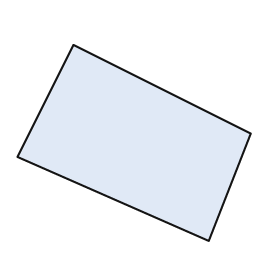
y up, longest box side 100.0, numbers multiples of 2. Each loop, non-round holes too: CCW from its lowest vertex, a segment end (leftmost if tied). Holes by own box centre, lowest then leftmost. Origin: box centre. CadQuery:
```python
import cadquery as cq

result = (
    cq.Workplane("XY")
    .moveTo(32.0, -42.0)
    .lineTo(50.0, 4.0)
    .lineTo(-26.0, 42.0)
    .lineTo(-50.0, -6.0)
    .close()
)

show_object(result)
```